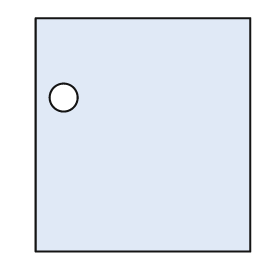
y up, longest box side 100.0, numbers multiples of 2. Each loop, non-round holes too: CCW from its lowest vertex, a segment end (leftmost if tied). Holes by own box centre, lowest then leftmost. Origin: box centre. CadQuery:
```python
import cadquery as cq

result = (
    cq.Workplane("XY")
    .moveTo(-46.0, -50.0)
    .lineTo(46.0, -50.0)
    .lineTo(46.0, 50.0)
    .lineTo(-46.0, 50.0)
    .close()
    .moveTo(-34.0, 16.0)
    .circle(6.0)
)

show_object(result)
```